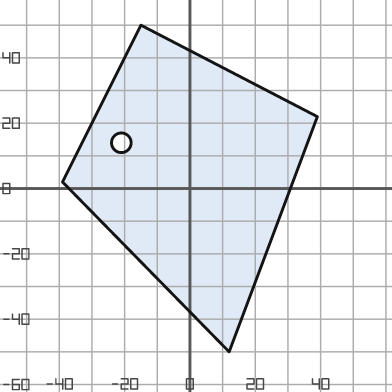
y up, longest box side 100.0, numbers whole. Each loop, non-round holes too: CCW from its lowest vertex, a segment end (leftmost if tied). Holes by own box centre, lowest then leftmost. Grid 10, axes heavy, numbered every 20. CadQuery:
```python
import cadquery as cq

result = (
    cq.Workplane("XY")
    .moveTo(12.0, -50.0)
    .lineTo(39.0, 22.0)
    .lineTo(-15.0, 50.0)
    .lineTo(-39.0, 2.0)
    .close()
    .moveTo(-21.0, 14.0)
    .circle(3.0)
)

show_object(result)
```